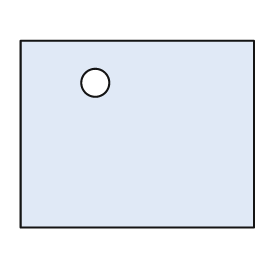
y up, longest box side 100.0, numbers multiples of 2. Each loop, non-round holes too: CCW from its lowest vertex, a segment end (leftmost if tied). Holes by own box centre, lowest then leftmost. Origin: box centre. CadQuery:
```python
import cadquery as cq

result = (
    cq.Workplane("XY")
    .moveTo(-50.0, -40.0)
    .lineTo(50.0, -40.0)
    .lineTo(50.0, 40.0)
    .lineTo(-50.0, 40.0)
    .close()
    .moveTo(-18.0, 22.0)
    .circle(6.0)
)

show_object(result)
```